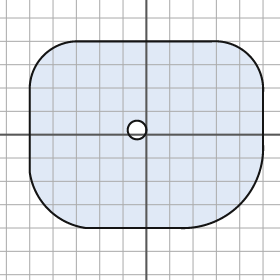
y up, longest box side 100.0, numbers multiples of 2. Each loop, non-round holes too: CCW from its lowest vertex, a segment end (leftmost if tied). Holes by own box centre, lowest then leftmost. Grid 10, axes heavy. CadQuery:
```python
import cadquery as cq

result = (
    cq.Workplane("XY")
    .moveTo(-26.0, -40.0)
    .lineTo(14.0, -40.0)
    .threePointArc((40.0, -30.0), (50.0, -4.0))
    .lineTo(50.0, 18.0)
    .threePointArc((44.0, 34.0), (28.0, 40.0))
    .lineTo(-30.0, 40.0)
    .threePointArc((-44.0, 34.0), (-50.0, 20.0))
    .lineTo(-50.0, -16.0)
    .threePointArc((-42.0, -32.0), (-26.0, -40.0))
    .close()
    .moveTo(-4.0, 2.0)
    .circle(4.0)
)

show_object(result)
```